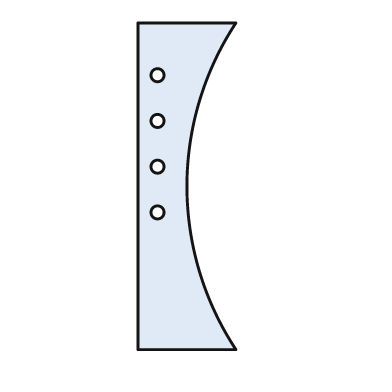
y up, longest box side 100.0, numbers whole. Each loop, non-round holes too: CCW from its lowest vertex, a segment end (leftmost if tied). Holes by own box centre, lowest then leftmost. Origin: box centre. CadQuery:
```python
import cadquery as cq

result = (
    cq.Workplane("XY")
    .moveTo(-15.0, -50.0)
    .lineTo(15.0, -50.0)
    .threePointArc((0.0, 0.0), (15.0, 50.0))
    .lineTo(-15.0, 50.0)
    .close()
    .moveTo(-9.0, -8.0)
    .circle(2.0)
    .moveTo(-9.0, 6.0)
    .circle(2.0)
    .moveTo(-9.0, 20.0)
    .circle(2.0)
    .moveTo(-9.0, 34.0)
    .circle(2.0)
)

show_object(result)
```